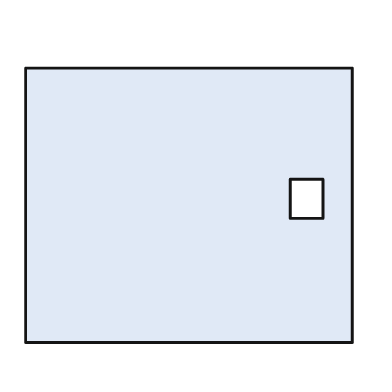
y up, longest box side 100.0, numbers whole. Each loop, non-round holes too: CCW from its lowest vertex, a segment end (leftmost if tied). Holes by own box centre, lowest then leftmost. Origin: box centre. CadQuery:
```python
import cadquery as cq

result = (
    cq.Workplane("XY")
    .moveTo(-50.0, -42.0)
    .lineTo(50.0, -42.0)
    .lineTo(50.0, 42.0)
    .lineTo(-50.0, 42.0)
    .close()
    .moveTo(31.0, -4.0)
    .lineTo(41.0, -4.0)
    .lineTo(41.0, 8.0)
    .lineTo(31.0, 8.0)
    .close()
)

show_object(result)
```